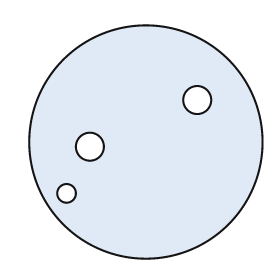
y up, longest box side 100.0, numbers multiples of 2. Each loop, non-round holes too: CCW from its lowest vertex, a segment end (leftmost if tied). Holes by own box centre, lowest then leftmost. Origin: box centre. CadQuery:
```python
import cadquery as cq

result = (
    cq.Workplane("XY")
    .moveTo(0.0, 0.0)
    .circle(50.0)
    .moveTo(-34.0, -22.0)
    .circle(4.0)
    .moveTo(-24.0, -2.0)
    .circle(6.0)
    .moveTo(22.0, 18.0)
    .circle(6.0)
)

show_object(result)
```